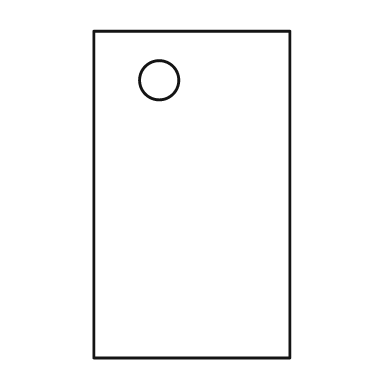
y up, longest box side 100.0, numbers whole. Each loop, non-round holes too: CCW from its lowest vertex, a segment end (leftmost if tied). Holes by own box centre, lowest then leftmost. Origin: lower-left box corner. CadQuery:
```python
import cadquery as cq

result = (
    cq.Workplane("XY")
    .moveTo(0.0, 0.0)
    .lineTo(60.0, 0.0)
    .lineTo(60.0, 100.0)
    .lineTo(0.0, 100.0)
    .close()
    .moveTo(20.0, 85.0)
    .circle(6.0)
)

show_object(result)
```